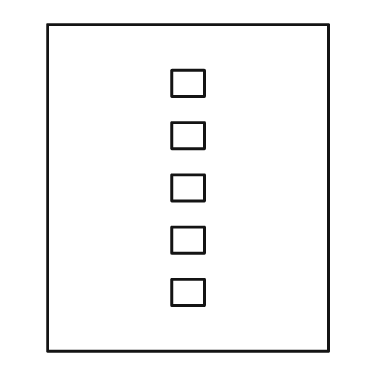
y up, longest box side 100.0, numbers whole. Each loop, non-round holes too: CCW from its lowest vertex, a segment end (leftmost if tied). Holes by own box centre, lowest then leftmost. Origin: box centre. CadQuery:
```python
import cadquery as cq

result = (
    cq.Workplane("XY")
    .moveTo(-43.0, -50.0)
    .lineTo(43.0, -50.0)
    .lineTo(43.0, 50.0)
    .lineTo(-43.0, 50.0)
    .close()
    .moveTo(-5.0, -36.0)
    .lineTo(5.0, -36.0)
    .lineTo(5.0, -28.0)
    .lineTo(-5.0, -28.0)
    .close()
    .moveTo(-5.0, -20.0)
    .lineTo(5.0, -20.0)
    .lineTo(5.0, -12.0)
    .lineTo(-5.0, -12.0)
    .close()
    .moveTo(-5.0, -4.0)
    .lineTo(5.0, -4.0)
    .lineTo(5.0, 4.0)
    .lineTo(-5.0, 4.0)
    .close()
    .moveTo(-5.0, 12.0)
    .lineTo(5.0, 12.0)
    .lineTo(5.0, 20.0)
    .lineTo(-5.0, 20.0)
    .close()
    .moveTo(-5.0, 28.0)
    .lineTo(5.0, 28.0)
    .lineTo(5.0, 36.0)
    .lineTo(-5.0, 36.0)
    .close()
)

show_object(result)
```